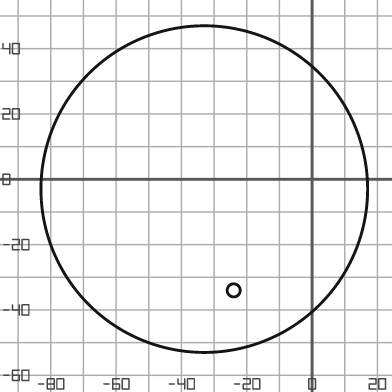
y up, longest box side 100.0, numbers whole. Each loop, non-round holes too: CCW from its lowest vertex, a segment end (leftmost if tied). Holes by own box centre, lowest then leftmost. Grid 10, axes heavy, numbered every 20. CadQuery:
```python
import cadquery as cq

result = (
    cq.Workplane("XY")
    .moveTo(-33.0, -3.0)
    .circle(50.0)
    .moveTo(-24.0, -34.0)
    .circle(2.0)
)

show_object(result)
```